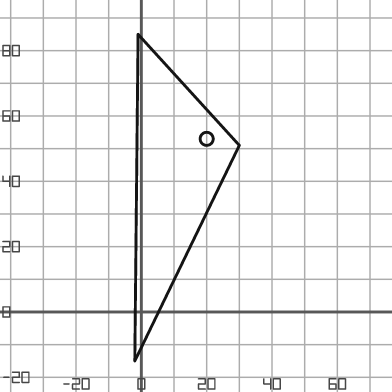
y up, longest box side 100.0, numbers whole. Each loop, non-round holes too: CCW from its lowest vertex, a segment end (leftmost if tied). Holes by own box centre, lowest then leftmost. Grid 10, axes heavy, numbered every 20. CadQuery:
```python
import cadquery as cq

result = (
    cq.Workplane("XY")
    .moveTo(-2.0, -15.0)
    .lineTo(30.0, 51.0)
    .lineTo(-1.0, 85.0)
    .close()
    .moveTo(20.0, 53.0)
    .circle(2.0)
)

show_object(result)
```